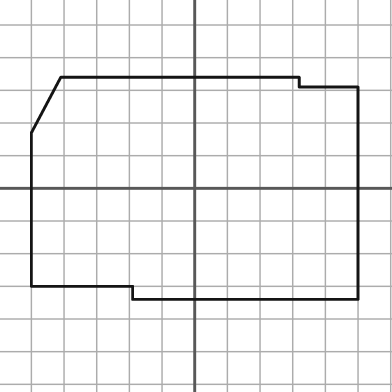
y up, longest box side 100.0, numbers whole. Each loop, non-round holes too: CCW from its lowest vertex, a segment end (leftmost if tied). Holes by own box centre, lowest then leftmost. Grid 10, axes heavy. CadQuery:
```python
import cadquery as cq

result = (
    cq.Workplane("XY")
    .moveTo(-19.0, -34.0)
    .lineTo(50.0, -34.0)
    .lineTo(50.0, 31.0)
    .lineTo(32.0, 31.0)
    .lineTo(32.0, 34.0)
    .lineTo(-41.0, 34.0)
    .lineTo(-50.0, 17.0)
    .lineTo(-50.0, -30.0)
    .lineTo(-19.0, -30.0)
    .close()
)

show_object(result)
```